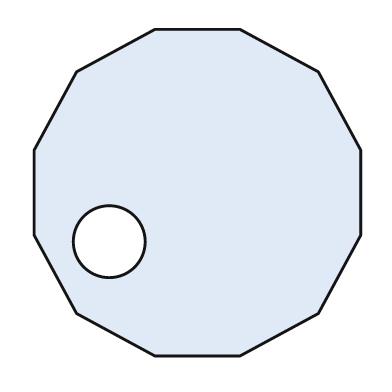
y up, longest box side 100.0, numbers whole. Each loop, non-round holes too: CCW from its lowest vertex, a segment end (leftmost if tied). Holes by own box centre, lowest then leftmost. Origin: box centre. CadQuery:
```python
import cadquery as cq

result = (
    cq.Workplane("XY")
    .moveTo(-13.0, -50.0)
    .lineTo(13.0, -50.0)
    .lineTo(37.0, -37.0)
    .lineTo(50.0, -13.0)
    .lineTo(50.0, 13.0)
    .lineTo(37.0, 37.0)
    .lineTo(13.0, 50.0)
    .lineTo(-13.0, 50.0)
    .lineTo(-37.0, 37.0)
    .lineTo(-50.0, 13.0)
    .lineTo(-50.0, -13.0)
    .lineTo(-37.0, -37.0)
    .close()
    .moveTo(-27.0, -15.0)
    .circle(11.0)
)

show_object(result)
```